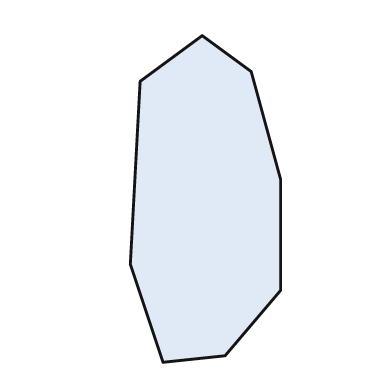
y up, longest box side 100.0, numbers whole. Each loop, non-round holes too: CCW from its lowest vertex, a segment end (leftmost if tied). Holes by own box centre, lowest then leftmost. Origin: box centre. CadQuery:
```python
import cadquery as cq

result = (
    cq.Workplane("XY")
    .moveTo(-13.0, -50.0)
    .lineTo(6.0, -48.0)
    .lineTo(23.0, -28.0)
    .lineTo(23.0, 6.0)
    .lineTo(14.0, 39.0)
    .lineTo(-1.0, 50.0)
    .lineTo(-20.0, 36.0)
    .lineTo(-23.0, -20.0)
    .close()
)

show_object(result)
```